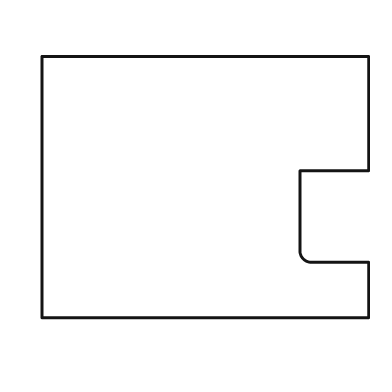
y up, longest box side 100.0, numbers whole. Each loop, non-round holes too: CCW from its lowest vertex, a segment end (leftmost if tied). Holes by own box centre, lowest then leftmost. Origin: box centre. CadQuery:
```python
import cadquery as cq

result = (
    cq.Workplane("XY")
    .moveTo(-50.0, -40.0)
    .lineTo(50.0, -40.0)
    .lineTo(50.0, -23.0)
    .lineTo(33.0, -23.0)
    .threePointArc((30.0, -22.0), (29.0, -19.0))
    .lineTo(29.0, 5.0)
    .lineTo(50.0, 5.0)
    .lineTo(50.0, 40.0)
    .lineTo(-50.0, 40.0)
    .close()
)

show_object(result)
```